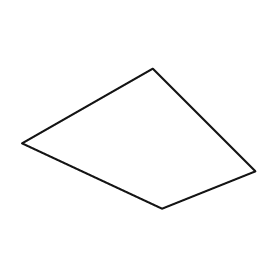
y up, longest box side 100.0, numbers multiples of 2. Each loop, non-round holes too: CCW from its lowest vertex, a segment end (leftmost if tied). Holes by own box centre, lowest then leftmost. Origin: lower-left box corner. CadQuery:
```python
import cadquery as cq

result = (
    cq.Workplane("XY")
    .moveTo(60.0, 0.0)
    .lineTo(100.0, 16.0)
    .lineTo(56.0, 60.0)
    .lineTo(0.0, 28.0)
    .close()
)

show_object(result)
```